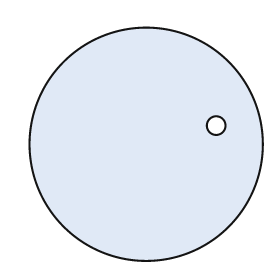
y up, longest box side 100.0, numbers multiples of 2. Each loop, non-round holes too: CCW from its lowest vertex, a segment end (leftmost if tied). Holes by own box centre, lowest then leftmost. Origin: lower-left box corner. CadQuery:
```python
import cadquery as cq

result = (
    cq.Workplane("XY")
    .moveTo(50.0, 50.0)
    .circle(50.0)
    .moveTo(80.0, 58.0)
    .circle(4.0)
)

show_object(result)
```